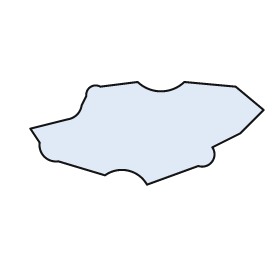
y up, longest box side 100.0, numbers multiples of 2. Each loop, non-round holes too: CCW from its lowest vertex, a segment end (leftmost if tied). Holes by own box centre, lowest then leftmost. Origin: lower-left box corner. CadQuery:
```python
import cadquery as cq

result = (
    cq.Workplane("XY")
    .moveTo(50.0, 0.0)
    .lineTo(72.0, 8.0)
    .threePointArc((78.0, 10.0), (78.0, 16.0))
    .lineTo(90.0, 22.0)
    .lineTo(100.0, 32.0)
    .lineTo(88.0, 42.0)
    .lineTo(66.0, 44.0)
    .threePointArc((56.0, 40.0), (46.0, 44.0))
    .lineTo(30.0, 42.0)
    .threePointArc((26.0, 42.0), (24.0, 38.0))
    .lineTo(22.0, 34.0)
    .threePointArc((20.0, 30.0), (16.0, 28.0))
    .lineTo(0.0, 24.0)
    .lineTo(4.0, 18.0)
    .threePointArc((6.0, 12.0), (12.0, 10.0))
    .lineTo(32.0, 4.0)
    .threePointArc((42.0, 6.0), (50.0, 0.0))
    .close()
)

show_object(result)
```